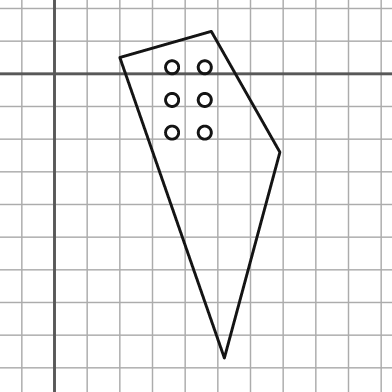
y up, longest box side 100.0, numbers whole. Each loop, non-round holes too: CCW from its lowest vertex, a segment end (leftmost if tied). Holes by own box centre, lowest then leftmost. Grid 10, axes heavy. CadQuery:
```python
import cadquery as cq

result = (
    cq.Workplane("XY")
    .moveTo(52.0, -87.0)
    .lineTo(69.0, -24.0)
    .lineTo(48.0, 13.0)
    .lineTo(20.0, 5.0)
    .close()
    .moveTo(36.0, -18.0)
    .circle(2.0)
    .moveTo(46.0, -18.0)
    .circle(2.0)
    .moveTo(36.0, -8.0)
    .circle(2.0)
    .moveTo(46.0, -8.0)
    .circle(2.0)
    .moveTo(36.0, 2.0)
    .circle(2.0)
    .moveTo(46.0, 2.0)
    .circle(2.0)
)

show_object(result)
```